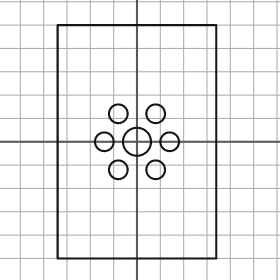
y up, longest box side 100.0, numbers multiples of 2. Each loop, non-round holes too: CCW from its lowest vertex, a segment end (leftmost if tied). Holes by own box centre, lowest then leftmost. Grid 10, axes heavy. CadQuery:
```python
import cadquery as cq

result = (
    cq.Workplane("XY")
    .moveTo(-34.0, -50.0)
    .lineTo(34.0, -50.0)
    .lineTo(34.0, 50.0)
    .lineTo(-34.0, 50.0)
    .close()
    .moveTo(-8.0, -12.0)
    .circle(4.0)
    .moveTo(8.0, -12.0)
    .circle(4.0)
    .moveTo(-14.0, 0.0)
    .circle(4.0)
    .moveTo(0.0, 0.0)
    .circle(6.0)
    .moveTo(14.0, 0.0)
    .circle(4.0)
    .moveTo(-8.0, 12.0)
    .circle(4.0)
    .moveTo(8.0, 12.0)
    .circle(4.0)
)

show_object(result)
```